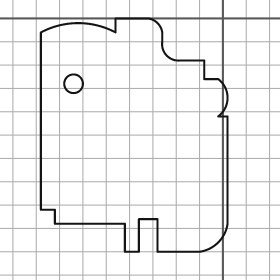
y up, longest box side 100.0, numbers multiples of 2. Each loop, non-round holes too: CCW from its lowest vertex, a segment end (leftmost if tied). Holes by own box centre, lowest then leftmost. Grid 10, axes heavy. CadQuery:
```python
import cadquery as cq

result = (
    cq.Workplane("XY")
    .moveTo(-42.0, -100.0)
    .lineTo(-36.0, -100.0)
    .lineTo(-36.0, -86.0)
    .lineTo(-28.0, -86.0)
    .lineTo(-28.0, -100.0)
    .lineTo(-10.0, -100.0)
    .threePointArc((-2.0, -96.0), (2.0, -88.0))
    .lineTo(2.0, -42.0)
    .lineTo(-2.0, -42.0)
    .threePointArc((2.0, -34.0), (-2.0, -26.0))
    .lineTo(-8.0, -26.0)
    .lineTo(-8.0, -18.0)
    .lineTo(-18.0, -18.0)
    .threePointArc((-24.0, -16.0), (-26.0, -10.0))
    .lineTo(-26.0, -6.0)
    .threePointArc((-28.0, -2.0), (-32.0, 0.0))
    .lineTo(-46.0, 0.0)
    .lineTo(-46.0, -6.0)
    .threePointArc((-62.0, -2.0), (-78.0, -6.0))
    .lineTo(-78.0, -82.0)
    .lineTo(-72.0, -82.0)
    .lineTo(-72.0, -88.0)
    .lineTo(-42.0, -88.0)
    .close()
    .moveTo(-64.0, -28.0)
    .circle(4.0)
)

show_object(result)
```